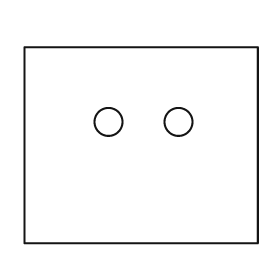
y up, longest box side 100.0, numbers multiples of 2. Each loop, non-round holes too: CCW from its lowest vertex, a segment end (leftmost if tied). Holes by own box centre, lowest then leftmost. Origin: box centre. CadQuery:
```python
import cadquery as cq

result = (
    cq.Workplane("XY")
    .moveTo(-50.0, -42.0)
    .lineTo(50.0, -42.0)
    .lineTo(50.0, 42.0)
    .lineTo(-50.0, 42.0)
    .close()
    .moveTo(-14.0, 10.0)
    .circle(6.0)
    .moveTo(16.0, 10.0)
    .circle(6.0)
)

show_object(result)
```